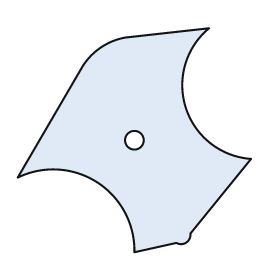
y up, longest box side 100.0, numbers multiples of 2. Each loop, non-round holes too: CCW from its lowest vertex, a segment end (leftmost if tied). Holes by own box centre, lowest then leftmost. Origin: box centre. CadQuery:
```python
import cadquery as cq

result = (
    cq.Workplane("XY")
    .moveTo(0.0, -48.0)
    .lineTo(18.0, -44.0)
    .threePointArc((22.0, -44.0), (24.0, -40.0))
    .lineTo(50.0, -8.0)
    .threePointArc((22.0, 14.0), (32.0, 48.0))
    .lineTo(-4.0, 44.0)
    .threePointArc((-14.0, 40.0), (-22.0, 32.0))
    .lineTo(-50.0, -16.0)
    .threePointArc((-16.0, -18.0), (0.0, -48.0))
    .close()
    .moveTo(0.0, 0.0)
    .circle(4.0)
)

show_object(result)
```